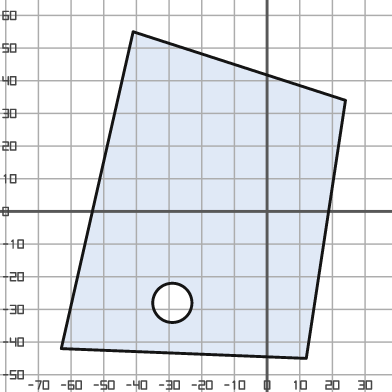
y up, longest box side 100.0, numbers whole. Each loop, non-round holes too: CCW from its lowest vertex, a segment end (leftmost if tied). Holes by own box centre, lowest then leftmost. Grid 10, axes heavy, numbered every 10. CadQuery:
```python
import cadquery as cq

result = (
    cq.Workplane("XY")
    .moveTo(12.0, -45.0)
    .lineTo(24.0, 34.0)
    .lineTo(-41.0, 55.0)
    .lineTo(-63.0, -42.0)
    .close()
    .moveTo(-29.0, -28.0)
    .circle(6.0)
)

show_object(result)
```